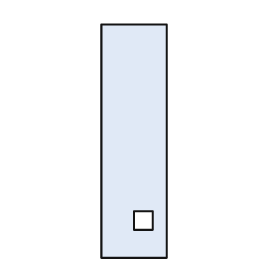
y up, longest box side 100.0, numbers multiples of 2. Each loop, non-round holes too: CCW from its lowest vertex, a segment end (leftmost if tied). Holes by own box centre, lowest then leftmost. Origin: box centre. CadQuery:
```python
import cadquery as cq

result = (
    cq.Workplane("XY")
    .moveTo(-14.0, -50.0)
    .lineTo(14.0, -50.0)
    .lineTo(14.0, 50.0)
    .lineTo(-14.0, 50.0)
    .close()
    .moveTo(0.0, -38.0)
    .lineTo(8.0, -38.0)
    .lineTo(8.0, -30.0)
    .lineTo(0.0, -30.0)
    .close()
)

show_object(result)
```